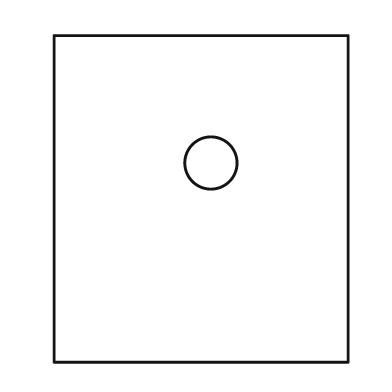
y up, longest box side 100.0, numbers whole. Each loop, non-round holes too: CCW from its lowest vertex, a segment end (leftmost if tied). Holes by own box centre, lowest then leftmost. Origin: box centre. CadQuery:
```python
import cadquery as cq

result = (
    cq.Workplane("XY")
    .moveTo(-45.0, -50.0)
    .lineTo(45.0, -50.0)
    .lineTo(45.0, 50.0)
    .lineTo(-45.0, 50.0)
    .close()
    .moveTo(3.0, 11.0)
    .circle(8.0)
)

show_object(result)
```